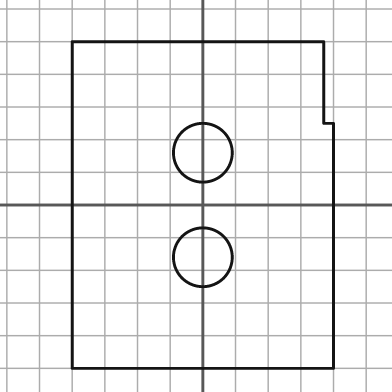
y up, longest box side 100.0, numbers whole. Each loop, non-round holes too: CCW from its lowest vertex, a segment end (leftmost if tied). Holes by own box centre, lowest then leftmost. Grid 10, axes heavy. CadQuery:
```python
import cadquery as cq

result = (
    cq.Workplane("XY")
    .moveTo(-40.0, -50.0)
    .lineTo(40.0, -50.0)
    .lineTo(40.0, 25.0)
    .lineTo(37.0, 25.0)
    .lineTo(37.0, 50.0)
    .lineTo(-40.0, 50.0)
    .close()
    .moveTo(0.0, -16.0)
    .circle(9.0)
    .moveTo(0.0, 16.0)
    .circle(9.0)
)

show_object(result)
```